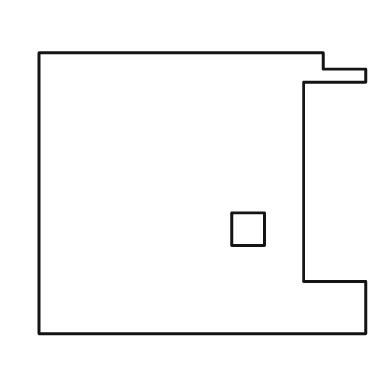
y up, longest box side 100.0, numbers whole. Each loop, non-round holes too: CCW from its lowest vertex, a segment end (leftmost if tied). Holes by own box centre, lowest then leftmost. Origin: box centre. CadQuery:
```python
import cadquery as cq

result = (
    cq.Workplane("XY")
    .moveTo(-50.0, -43.0)
    .lineTo(50.0, -43.0)
    .lineTo(50.0, -27.0)
    .lineTo(31.0, -27.0)
    .lineTo(31.0, 34.0)
    .lineTo(50.0, 34.0)
    .lineTo(50.0, 38.0)
    .lineTo(37.0, 38.0)
    .lineTo(37.0, 43.0)
    .lineTo(-50.0, 43.0)
    .close()
    .moveTo(9.0, -16.0)
    .lineTo(19.0, -16.0)
    .lineTo(19.0, -6.0)
    .lineTo(9.0, -6.0)
    .close()
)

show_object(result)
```